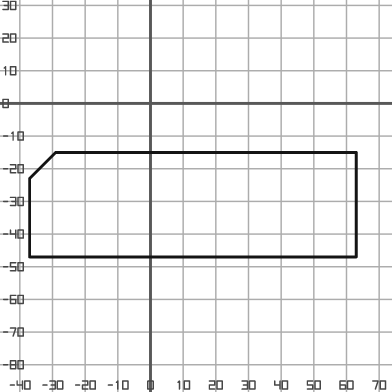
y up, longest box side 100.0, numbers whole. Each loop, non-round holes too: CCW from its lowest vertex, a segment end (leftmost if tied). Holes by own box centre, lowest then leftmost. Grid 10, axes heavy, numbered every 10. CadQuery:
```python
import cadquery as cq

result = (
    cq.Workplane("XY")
    .moveTo(-37.0, -47.0)
    .lineTo(63.0, -47.0)
    .lineTo(63.0, -15.0)
    .lineTo(-29.0, -15.0)
    .lineTo(-37.0, -23.0)
    .close()
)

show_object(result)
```